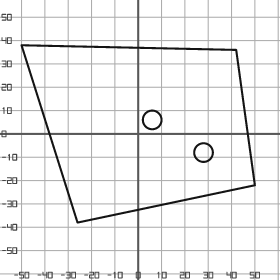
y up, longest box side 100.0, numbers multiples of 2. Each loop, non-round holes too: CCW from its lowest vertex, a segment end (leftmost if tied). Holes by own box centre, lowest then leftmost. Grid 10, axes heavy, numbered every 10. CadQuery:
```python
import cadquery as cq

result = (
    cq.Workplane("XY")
    .moveTo(-26.0, -38.0)
    .lineTo(50.0, -22.0)
    .lineTo(42.0, 36.0)
    .lineTo(-50.0, 38.0)
    .close()
    .moveTo(28.0, -8.0)
    .circle(4.0)
    .moveTo(6.0, 6.0)
    .circle(4.0)
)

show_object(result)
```